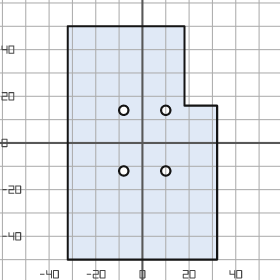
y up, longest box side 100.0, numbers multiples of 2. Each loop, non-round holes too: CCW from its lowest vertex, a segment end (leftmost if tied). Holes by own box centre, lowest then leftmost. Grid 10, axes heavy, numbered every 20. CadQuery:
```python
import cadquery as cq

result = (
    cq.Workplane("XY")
    .moveTo(-32.0, -50.0)
    .lineTo(32.0, -50.0)
    .lineTo(32.0, 16.0)
    .lineTo(18.0, 16.0)
    .lineTo(18.0, 50.0)
    .lineTo(-32.0, 50.0)
    .close()
    .moveTo(-8.0, -12.0)
    .circle(2.0)
    .moveTo(10.0, -12.0)
    .circle(2.0)
    .moveTo(-8.0, 14.0)
    .circle(2.0)
    .moveTo(10.0, 14.0)
    .circle(2.0)
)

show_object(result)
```